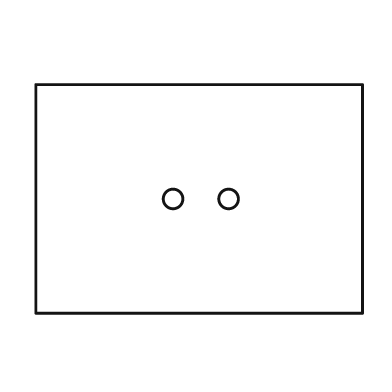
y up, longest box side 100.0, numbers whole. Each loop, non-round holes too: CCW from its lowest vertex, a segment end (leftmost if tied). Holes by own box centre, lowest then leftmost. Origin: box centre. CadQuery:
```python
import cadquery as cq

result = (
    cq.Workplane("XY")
    .moveTo(-50.0, -35.0)
    .lineTo(50.0, -35.0)
    .lineTo(50.0, 35.0)
    .lineTo(-50.0, 35.0)
    .close()
    .moveTo(-8.0, 0.0)
    .circle(3.0)
    .moveTo(9.0, 0.0)
    .circle(3.0)
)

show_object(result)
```